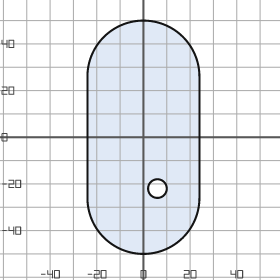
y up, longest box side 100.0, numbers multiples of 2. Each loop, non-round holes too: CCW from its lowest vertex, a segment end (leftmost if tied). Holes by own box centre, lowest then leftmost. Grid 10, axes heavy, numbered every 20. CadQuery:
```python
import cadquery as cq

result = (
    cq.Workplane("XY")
    .moveTo(-24.0, -26.0)
    .threePointArc((0.0, -50.0), (24.0, -26.0))
    .lineTo(24.0, 26.0)
    .threePointArc((0.0, 50.0), (-24.0, 26.0))
    .close()
    .moveTo(6.0, -22.0)
    .circle(4.0)
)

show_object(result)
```